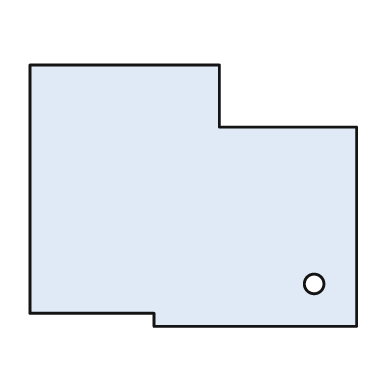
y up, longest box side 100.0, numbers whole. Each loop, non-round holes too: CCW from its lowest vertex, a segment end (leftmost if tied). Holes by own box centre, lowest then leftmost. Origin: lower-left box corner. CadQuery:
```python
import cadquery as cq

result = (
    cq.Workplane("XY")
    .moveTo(38.0, 0.0)
    .lineTo(100.0, 0.0)
    .lineTo(100.0, 61.0)
    .lineTo(58.0, 61.0)
    .lineTo(58.0, 80.0)
    .lineTo(0.0, 80.0)
    .lineTo(0.0, 4.0)
    .lineTo(38.0, 4.0)
    .close()
    .moveTo(87.0, 13.0)
    .circle(3.0)
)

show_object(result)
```